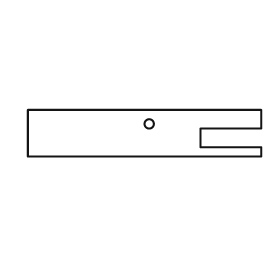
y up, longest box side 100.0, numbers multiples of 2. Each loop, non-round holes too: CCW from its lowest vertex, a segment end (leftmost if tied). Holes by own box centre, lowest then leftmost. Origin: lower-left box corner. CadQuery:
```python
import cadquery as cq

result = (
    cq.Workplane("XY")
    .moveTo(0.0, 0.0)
    .lineTo(100.0, 0.0)
    .lineTo(100.0, 4.0)
    .lineTo(74.0, 4.0)
    .lineTo(74.0, 12.0)
    .lineTo(100.0, 12.0)
    .lineTo(100.0, 20.0)
    .lineTo(0.0, 20.0)
    .close()
    .moveTo(52.0, 14.0)
    .circle(2.0)
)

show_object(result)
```